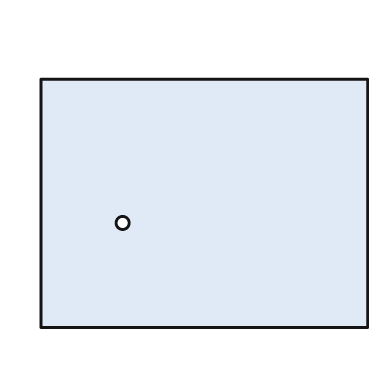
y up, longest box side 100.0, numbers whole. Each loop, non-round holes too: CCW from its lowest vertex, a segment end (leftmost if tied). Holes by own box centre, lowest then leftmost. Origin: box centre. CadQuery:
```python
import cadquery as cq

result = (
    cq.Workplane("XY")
    .moveTo(-50.0, -38.0)
    .lineTo(50.0, -38.0)
    .lineTo(50.0, 38.0)
    .lineTo(-50.0, 38.0)
    .close()
    .moveTo(-25.0, -6.0)
    .circle(2.0)
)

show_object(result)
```